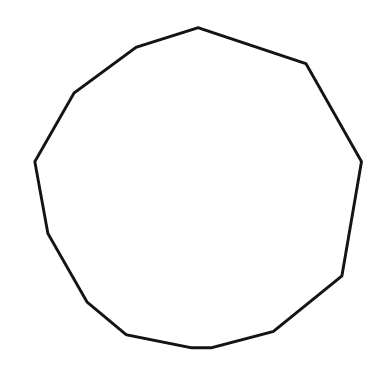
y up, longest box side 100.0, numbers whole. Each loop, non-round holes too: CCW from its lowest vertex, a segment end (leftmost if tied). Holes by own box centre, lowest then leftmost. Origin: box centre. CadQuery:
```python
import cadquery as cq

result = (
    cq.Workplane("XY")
    .moveTo(-2.0, -49.0)
    .lineTo(4.0, -49.0)
    .lineTo(23.0, -44.0)
    .lineTo(44.0, -27.0)
    .lineTo(50.0, 8.0)
    .lineTo(33.0, 38.0)
    .lineTo(0.0, 49.0)
    .lineTo(-19.0, 43.0)
    .lineTo(-38.0, 29.0)
    .lineTo(-50.0, 8.0)
    .lineTo(-46.0, -14.0)
    .lineTo(-34.0, -35.0)
    .lineTo(-22.0, -45.0)
    .close()
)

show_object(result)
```